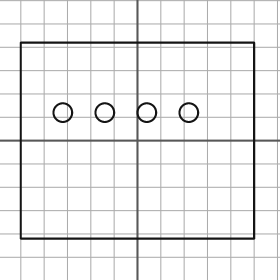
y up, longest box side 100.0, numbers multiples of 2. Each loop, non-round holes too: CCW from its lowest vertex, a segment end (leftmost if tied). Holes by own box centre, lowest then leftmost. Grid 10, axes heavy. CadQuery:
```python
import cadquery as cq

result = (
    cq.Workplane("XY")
    .moveTo(-50.0, -42.0)
    .lineTo(50.0, -42.0)
    .lineTo(50.0, 42.0)
    .lineTo(-50.0, 42.0)
    .close()
    .moveTo(-32.0, 12.0)
    .circle(4.0)
    .moveTo(-14.0, 12.0)
    .circle(4.0)
    .moveTo(4.0, 12.0)
    .circle(4.0)
    .moveTo(22.0, 12.0)
    .circle(4.0)
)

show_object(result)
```